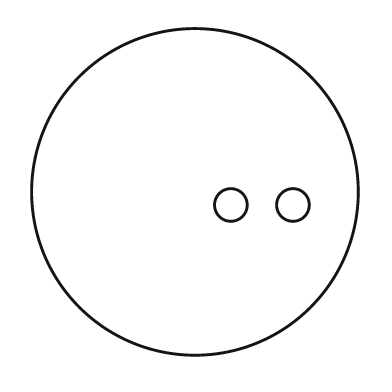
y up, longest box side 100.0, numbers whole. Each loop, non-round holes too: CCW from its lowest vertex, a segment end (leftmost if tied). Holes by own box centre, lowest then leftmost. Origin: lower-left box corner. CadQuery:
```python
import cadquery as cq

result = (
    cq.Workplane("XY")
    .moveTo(50.0, 50.0)
    .circle(50.0)
    .moveTo(61.0, 46.0)
    .circle(5.0)
    .moveTo(80.0, 46.0)
    .circle(5.0)
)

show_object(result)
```